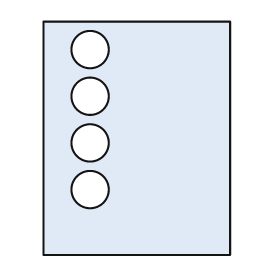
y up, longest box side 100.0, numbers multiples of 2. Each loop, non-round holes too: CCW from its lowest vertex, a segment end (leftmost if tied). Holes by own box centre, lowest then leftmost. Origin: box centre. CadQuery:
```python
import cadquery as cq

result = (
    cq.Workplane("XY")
    .moveTo(-40.0, -50.0)
    .lineTo(40.0, -50.0)
    .lineTo(40.0, 50.0)
    .lineTo(-40.0, 50.0)
    .close()
    .moveTo(-20.0, -22.0)
    .circle(8.0)
    .moveTo(-20.0, -2.0)
    .circle(8.0)
    .moveTo(-20.0, 18.0)
    .circle(8.0)
    .moveTo(-20.0, 38.0)
    .circle(8.0)
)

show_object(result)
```